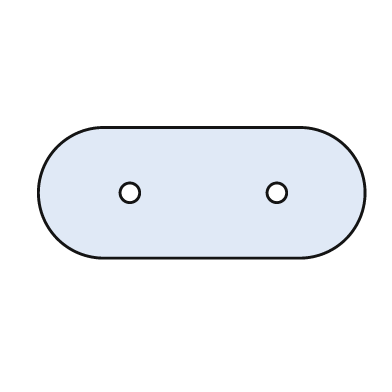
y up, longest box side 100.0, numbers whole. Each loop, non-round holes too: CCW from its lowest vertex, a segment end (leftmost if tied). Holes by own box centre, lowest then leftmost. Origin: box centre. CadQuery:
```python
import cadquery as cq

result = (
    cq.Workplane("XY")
    .moveTo(-30.0, -20.0)
    .lineTo(30.0, -20.0)
    .threePointArc((50.0, 0.0), (30.0, 20.0))
    .lineTo(-30.0, 20.0)
    .threePointArc((-50.0, 0.0), (-30.0, -20.0))
    .close()
    .moveTo(-22.0, 0.0)
    .circle(3.0)
    .moveTo(23.0, 0.0)
    .circle(3.0)
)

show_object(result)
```